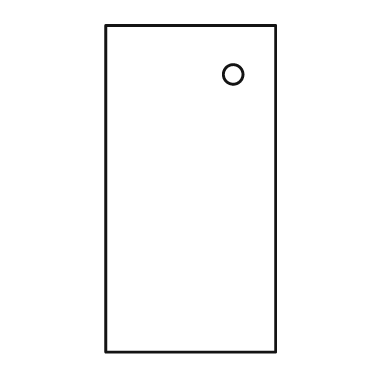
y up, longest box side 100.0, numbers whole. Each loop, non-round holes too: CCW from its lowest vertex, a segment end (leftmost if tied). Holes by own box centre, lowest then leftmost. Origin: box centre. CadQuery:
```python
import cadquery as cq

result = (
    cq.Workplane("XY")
    .moveTo(-26.0, -50.0)
    .lineTo(26.0, -50.0)
    .lineTo(26.0, 50.0)
    .lineTo(-26.0, 50.0)
    .close()
    .moveTo(13.0, 35.0)
    .circle(3.0)
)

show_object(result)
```